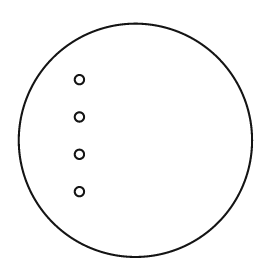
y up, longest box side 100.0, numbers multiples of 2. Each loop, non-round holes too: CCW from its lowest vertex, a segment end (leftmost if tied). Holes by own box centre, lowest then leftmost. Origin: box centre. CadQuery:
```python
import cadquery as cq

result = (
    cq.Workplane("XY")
    .moveTo(0.0, 0.0)
    .circle(50.0)
    .moveTo(-24.0, -22.0)
    .circle(2.0)
    .moveTo(-24.0, -6.0)
    .circle(2.0)
    .moveTo(-24.0, 10.0)
    .circle(2.0)
    .moveTo(-24.0, 26.0)
    .circle(2.0)
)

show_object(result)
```